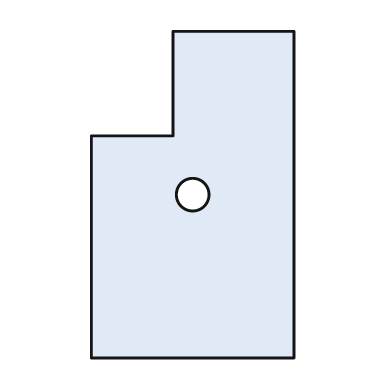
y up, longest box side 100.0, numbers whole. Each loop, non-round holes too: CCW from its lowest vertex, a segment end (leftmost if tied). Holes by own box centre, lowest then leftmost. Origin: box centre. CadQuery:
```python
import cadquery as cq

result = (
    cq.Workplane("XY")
    .moveTo(-31.0, -50.0)
    .lineTo(31.0, -50.0)
    .lineTo(31.0, 50.0)
    .lineTo(-6.0, 50.0)
    .lineTo(-6.0, 18.0)
    .lineTo(-31.0, 18.0)
    .close()
    .moveTo(0.0, 0.0)
    .circle(5.0)
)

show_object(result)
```